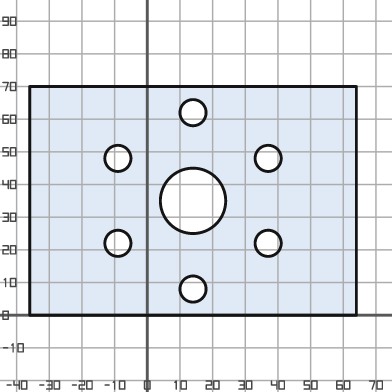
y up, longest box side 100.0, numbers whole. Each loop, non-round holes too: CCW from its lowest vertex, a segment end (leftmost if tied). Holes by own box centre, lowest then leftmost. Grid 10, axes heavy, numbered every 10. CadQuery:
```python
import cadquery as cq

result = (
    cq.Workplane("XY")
    .moveTo(-36.0, 0.0)
    .lineTo(64.0, 0.0)
    .lineTo(64.0, 70.0)
    .lineTo(-36.0, 70.0)
    .close()
    .moveTo(14.0, 8.0)
    .circle(4.0)
    .moveTo(-9.0, 22.0)
    .circle(4.0)
    .moveTo(37.0, 22.0)
    .circle(4.0)
    .moveTo(14.0, 35.0)
    .circle(10.0)
    .moveTo(-9.0, 48.0)
    .circle(4.0)
    .moveTo(37.0, 48.0)
    .circle(4.0)
    .moveTo(14.0, 62.0)
    .circle(4.0)
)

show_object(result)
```